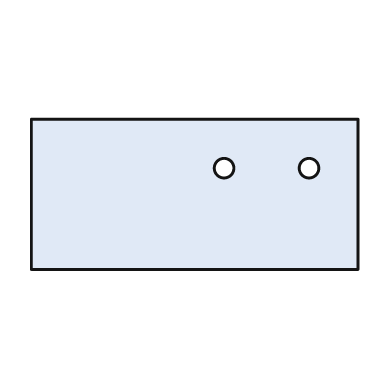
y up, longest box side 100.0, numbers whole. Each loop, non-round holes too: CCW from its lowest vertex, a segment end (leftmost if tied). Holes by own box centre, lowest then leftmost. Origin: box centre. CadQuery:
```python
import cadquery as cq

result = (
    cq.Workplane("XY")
    .moveTo(-50.0, -23.0)
    .lineTo(50.0, -23.0)
    .lineTo(50.0, 23.0)
    .lineTo(-50.0, 23.0)
    .close()
    .moveTo(9.0, 8.0)
    .circle(3.0)
    .moveTo(35.0, 8.0)
    .circle(3.0)
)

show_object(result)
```